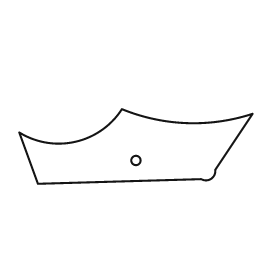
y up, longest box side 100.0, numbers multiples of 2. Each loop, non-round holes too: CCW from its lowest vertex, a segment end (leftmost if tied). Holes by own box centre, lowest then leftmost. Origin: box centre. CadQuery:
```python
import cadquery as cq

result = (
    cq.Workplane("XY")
    .moveTo(-42.0, -16.0)
    .lineTo(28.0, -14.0)
    .threePointArc((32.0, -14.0), (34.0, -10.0))
    .lineTo(50.0, 14.0)
    .threePointArc((22.0, 10.0), (-6.0, 16.0))
    .threePointArc((-26.0, 2.0), (-50.0, 6.0))
    .close()
    .moveTo(0.0, -6.0)
    .circle(2.0)
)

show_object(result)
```